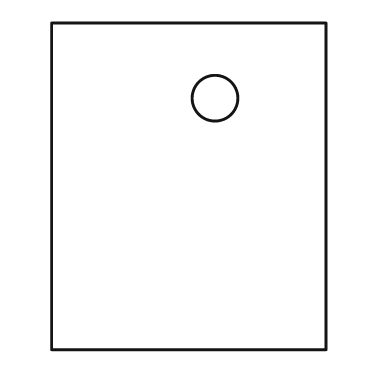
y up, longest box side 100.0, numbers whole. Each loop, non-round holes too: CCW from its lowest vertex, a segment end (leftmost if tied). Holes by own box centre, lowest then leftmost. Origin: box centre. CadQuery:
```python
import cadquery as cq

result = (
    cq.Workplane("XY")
    .moveTo(-42.0, -50.0)
    .lineTo(42.0, -50.0)
    .lineTo(42.0, 50.0)
    .lineTo(-42.0, 50.0)
    .close()
    .moveTo(8.0, 27.0)
    .circle(7.0)
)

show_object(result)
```